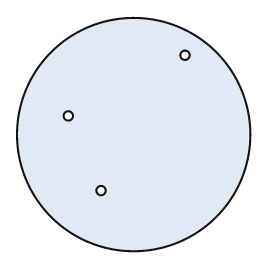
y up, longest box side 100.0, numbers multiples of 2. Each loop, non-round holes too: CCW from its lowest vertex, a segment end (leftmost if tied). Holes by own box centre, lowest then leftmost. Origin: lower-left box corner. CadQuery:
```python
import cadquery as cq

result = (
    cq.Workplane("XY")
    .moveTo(50.0, 50.0)
    .circle(50.0)
    .moveTo(36.0, 26.0)
    .circle(2.0)
    .moveTo(22.0, 58.0)
    .circle(2.0)
    .moveTo(72.0, 84.0)
    .circle(2.0)
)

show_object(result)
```